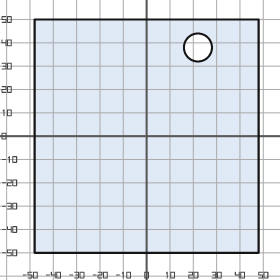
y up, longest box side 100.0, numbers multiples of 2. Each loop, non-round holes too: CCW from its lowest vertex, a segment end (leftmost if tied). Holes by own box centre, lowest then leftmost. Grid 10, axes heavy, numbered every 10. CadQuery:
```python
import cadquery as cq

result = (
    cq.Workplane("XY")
    .moveTo(-48.0, -50.0)
    .lineTo(48.0, -50.0)
    .lineTo(48.0, 50.0)
    .lineTo(-48.0, 50.0)
    .close()
    .moveTo(22.0, 38.0)
    .circle(6.0)
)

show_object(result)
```